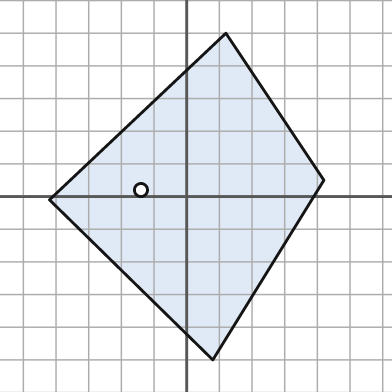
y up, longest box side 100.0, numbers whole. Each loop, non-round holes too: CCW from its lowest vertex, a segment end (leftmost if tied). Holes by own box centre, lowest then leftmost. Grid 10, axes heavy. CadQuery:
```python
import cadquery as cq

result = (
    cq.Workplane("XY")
    .moveTo(8.0, -50.0)
    .lineTo(42.0, 5.0)
    .lineTo(12.0, 50.0)
    .lineTo(-42.0, -1.0)
    .close()
    .moveTo(-14.0, 2.0)
    .circle(2.0)
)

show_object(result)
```